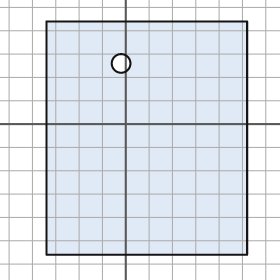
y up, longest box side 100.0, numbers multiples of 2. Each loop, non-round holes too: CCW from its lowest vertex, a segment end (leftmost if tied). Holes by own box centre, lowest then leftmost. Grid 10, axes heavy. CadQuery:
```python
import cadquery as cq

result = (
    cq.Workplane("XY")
    .moveTo(-34.0, -56.0)
    .lineTo(52.0, -56.0)
    .lineTo(52.0, 44.0)
    .lineTo(-34.0, 44.0)
    .close()
    .moveTo(-2.0, 26.0)
    .circle(4.0)
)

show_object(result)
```